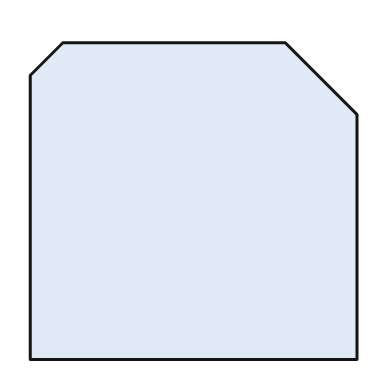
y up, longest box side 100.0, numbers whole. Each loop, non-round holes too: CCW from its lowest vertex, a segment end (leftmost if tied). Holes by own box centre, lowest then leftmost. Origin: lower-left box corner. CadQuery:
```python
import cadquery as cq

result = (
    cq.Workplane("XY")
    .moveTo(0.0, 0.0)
    .lineTo(100.0, 0.0)
    .lineTo(100.0, 75.0)
    .lineTo(78.0, 97.0)
    .lineTo(10.0, 97.0)
    .lineTo(0.0, 87.0)
    .close()
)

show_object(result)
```